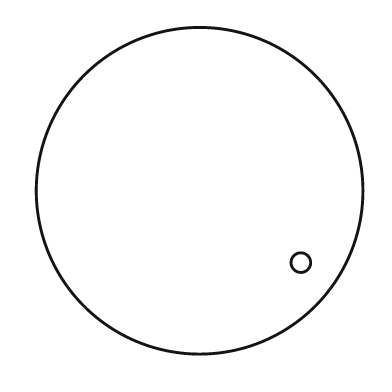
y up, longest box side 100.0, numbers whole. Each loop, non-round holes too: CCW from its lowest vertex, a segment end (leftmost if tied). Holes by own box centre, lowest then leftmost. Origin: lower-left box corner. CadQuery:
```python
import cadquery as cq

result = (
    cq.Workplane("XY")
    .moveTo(50.0, 50.0)
    .circle(50.0)
    .moveTo(81.0, 28.0)
    .circle(3.0)
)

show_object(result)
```